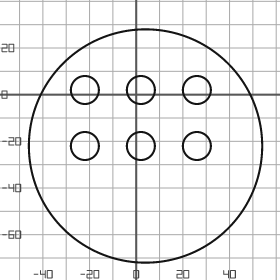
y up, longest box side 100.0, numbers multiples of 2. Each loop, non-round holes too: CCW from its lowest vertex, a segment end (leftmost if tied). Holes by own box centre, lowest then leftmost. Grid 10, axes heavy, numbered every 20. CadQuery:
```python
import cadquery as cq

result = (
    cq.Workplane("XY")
    .moveTo(4.0, -22.0)
    .circle(50.0)
    .moveTo(-22.0, -22.0)
    .circle(6.0)
    .moveTo(2.0, -22.0)
    .circle(6.0)
    .moveTo(26.0, -22.0)
    .circle(6.0)
    .moveTo(-22.0, 2.0)
    .circle(6.0)
    .moveTo(2.0, 2.0)
    .circle(6.0)
    .moveTo(26.0, 2.0)
    .circle(6.0)
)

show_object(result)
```